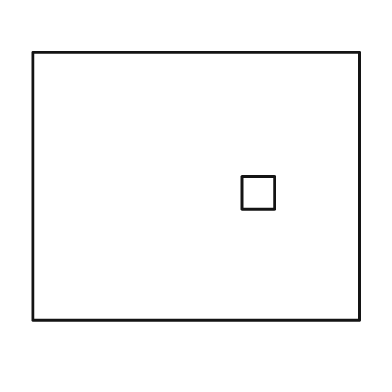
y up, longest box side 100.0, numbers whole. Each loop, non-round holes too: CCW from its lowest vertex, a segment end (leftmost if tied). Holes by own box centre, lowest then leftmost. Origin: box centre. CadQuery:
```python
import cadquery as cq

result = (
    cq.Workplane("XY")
    .moveTo(-50.0, -41.0)
    .lineTo(50.0, -41.0)
    .lineTo(50.0, 41.0)
    .lineTo(-50.0, 41.0)
    .close()
    .moveTo(14.0, -7.0)
    .lineTo(24.0, -7.0)
    .lineTo(24.0, 3.0)
    .lineTo(14.0, 3.0)
    .close()
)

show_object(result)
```